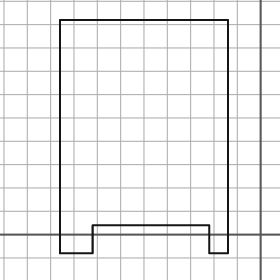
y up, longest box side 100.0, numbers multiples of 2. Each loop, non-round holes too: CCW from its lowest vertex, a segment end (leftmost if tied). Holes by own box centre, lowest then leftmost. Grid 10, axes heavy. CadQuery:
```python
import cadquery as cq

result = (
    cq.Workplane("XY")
    .moveTo(-86.0, -8.0)
    .lineTo(-72.0, -8.0)
    .lineTo(-72.0, 4.0)
    .lineTo(-22.0, 4.0)
    .lineTo(-22.0, -8.0)
    .lineTo(-14.0, -8.0)
    .lineTo(-14.0, 92.0)
    .lineTo(-86.0, 92.0)
    .close()
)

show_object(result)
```